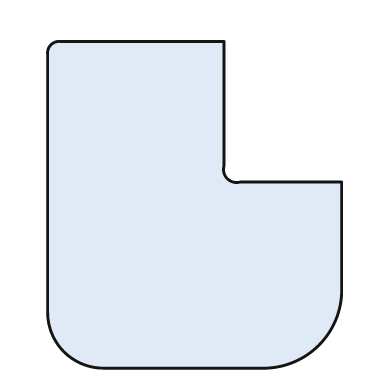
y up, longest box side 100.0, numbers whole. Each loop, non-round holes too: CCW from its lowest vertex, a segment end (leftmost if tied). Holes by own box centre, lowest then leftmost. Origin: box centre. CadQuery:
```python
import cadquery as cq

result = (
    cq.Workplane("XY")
    .moveTo(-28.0, -50.0)
    .lineTo(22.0, -50.0)
    .threePointArc((38.0, -43.0), (45.0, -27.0))
    .lineTo(45.0, 7.0)
    .lineTo(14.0, 7.0)
    .threePointArc((10.0, 8.0), (9.0, 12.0))
    .lineTo(9.0, 50.0)
    .lineTo(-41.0, 50.0)
    .threePointArc((-44.0, 49.0), (-45.0, 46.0))
    .lineTo(-45.0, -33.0)
    .threePointArc((-40.0, -45.0), (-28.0, -50.0))
    .close()
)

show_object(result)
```